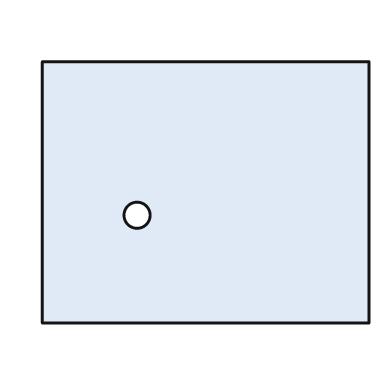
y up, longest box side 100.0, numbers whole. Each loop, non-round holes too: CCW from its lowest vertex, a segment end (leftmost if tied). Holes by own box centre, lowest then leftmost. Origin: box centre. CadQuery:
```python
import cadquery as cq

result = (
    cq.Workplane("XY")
    .moveTo(-50.0, -40.0)
    .lineTo(50.0, -40.0)
    .lineTo(50.0, 40.0)
    .lineTo(-50.0, 40.0)
    .close()
    .moveTo(-21.0, -7.0)
    .circle(4.0)
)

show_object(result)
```